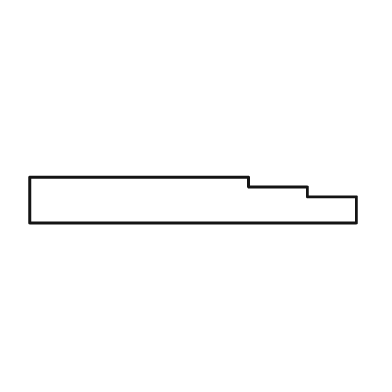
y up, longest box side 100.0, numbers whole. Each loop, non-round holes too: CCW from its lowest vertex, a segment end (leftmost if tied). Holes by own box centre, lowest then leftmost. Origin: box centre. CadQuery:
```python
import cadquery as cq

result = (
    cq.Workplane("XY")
    .moveTo(-50.0, -7.0)
    .lineTo(50.0, -7.0)
    .lineTo(50.0, 1.0)
    .lineTo(35.0, 1.0)
    .lineTo(35.0, 4.0)
    .lineTo(17.0, 4.0)
    .lineTo(17.0, 7.0)
    .lineTo(-50.0, 7.0)
    .close()
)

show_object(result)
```